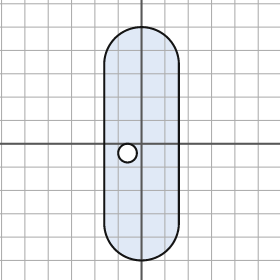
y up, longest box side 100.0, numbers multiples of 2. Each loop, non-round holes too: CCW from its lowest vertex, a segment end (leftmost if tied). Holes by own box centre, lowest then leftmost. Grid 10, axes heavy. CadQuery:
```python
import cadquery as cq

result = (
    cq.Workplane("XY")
    .moveTo(-16.0, -34.0)
    .threePointArc((0.0, -50.0), (16.0, -34.0))
    .lineTo(16.0, 34.0)
    .threePointArc((0.0, 50.0), (-16.0, 34.0))
    .close()
    .moveTo(-6.0, -4.0)
    .circle(4.0)
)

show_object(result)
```